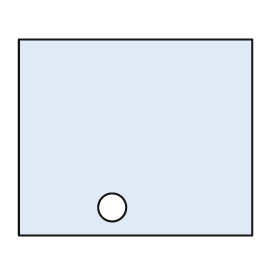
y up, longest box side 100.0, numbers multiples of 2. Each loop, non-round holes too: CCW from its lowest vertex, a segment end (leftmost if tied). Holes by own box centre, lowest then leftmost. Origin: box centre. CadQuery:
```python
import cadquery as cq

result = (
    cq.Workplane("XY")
    .moveTo(-50.0, -42.0)
    .lineTo(50.0, -42.0)
    .lineTo(50.0, 42.0)
    .lineTo(-50.0, 42.0)
    .close()
    .moveTo(-10.0, -30.0)
    .circle(6.0)
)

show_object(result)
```